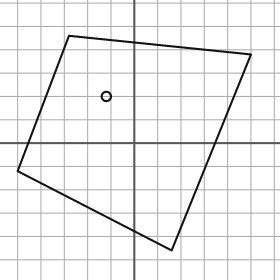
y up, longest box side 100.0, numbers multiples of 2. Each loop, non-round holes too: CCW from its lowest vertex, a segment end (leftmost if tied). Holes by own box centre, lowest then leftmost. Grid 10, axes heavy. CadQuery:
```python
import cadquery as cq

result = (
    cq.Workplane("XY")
    .moveTo(16.0, -46.0)
    .lineTo(50.0, 38.0)
    .lineTo(-28.0, 46.0)
    .lineTo(-50.0, -12.0)
    .close()
    .moveTo(-12.0, 20.0)
    .circle(2.0)
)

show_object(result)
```